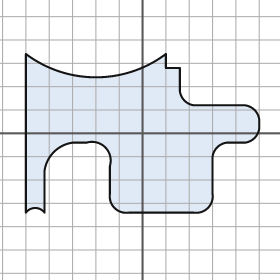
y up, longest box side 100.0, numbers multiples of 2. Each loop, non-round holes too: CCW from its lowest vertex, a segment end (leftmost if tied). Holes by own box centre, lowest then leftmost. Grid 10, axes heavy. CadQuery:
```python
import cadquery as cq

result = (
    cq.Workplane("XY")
    .moveTo(-50.0, -34.0)
    .threePointArc((-46.0, -32.0), (-42.0, -34.0))
    .lineTo(-42.0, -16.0)
    .threePointArc((-38.0, -8.0), (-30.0, -4.0))
    .lineTo(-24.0, -4.0)
    .threePointArc((-16.0, -6.0), (-14.0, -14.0))
    .lineTo(-14.0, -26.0)
    .threePointArc((-12.0, -32.0), (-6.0, -34.0))
    .lineTo(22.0, -34.0)
    .threePointArc((28.0, -32.0), (30.0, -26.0))
    .lineTo(30.0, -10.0)
    .threePointArc((32.0, -6.0), (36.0, -4.0))
    .lineTo(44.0, -4.0)
    .threePointArc((48.0, -2.0), (50.0, 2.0))
    .lineTo(50.0, 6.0)
    .threePointArc((48.0, 10.0), (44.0, 12.0))
    .lineTo(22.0, 12.0)
    .threePointArc((18.0, 14.0), (16.0, 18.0))
    .lineTo(16.0, 28.0)
    .lineTo(10.0, 28.0)
    .lineTo(10.0, 34.0)
    .threePointArc((-20.0, 24.0), (-50.0, 34.0))
    .close()
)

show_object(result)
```